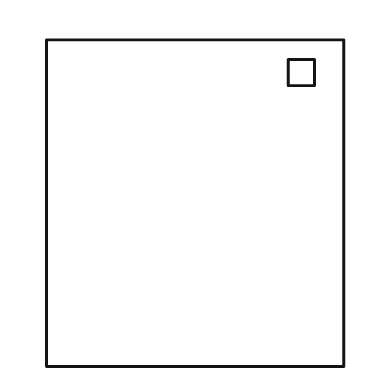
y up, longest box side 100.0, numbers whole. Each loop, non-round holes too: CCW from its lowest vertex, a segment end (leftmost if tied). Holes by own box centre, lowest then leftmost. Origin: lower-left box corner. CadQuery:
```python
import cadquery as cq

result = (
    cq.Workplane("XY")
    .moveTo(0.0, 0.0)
    .lineTo(91.0, 0.0)
    .lineTo(91.0, 100.0)
    .lineTo(0.0, 100.0)
    .close()
    .moveTo(74.0, 86.0)
    .lineTo(82.0, 86.0)
    .lineTo(82.0, 94.0)
    .lineTo(74.0, 94.0)
    .close()
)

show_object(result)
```